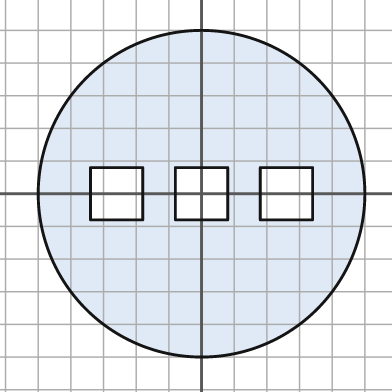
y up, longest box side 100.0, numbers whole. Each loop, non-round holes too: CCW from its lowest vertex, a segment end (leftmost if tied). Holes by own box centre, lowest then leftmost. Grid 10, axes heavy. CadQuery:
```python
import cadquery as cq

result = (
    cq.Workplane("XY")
    .moveTo(0.0, 0.0)
    .circle(50.0)
    .moveTo(-34.0, -8.0)
    .lineTo(-18.0, -8.0)
    .lineTo(-18.0, 8.0)
    .lineTo(-34.0, 8.0)
    .close()
    .moveTo(-8.0, -8.0)
    .lineTo(8.0, -8.0)
    .lineTo(8.0, 8.0)
    .lineTo(-8.0, 8.0)
    .close()
    .moveTo(18.0, -8.0)
    .lineTo(34.0, -8.0)
    .lineTo(34.0, 8.0)
    .lineTo(18.0, 8.0)
    .close()
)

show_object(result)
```